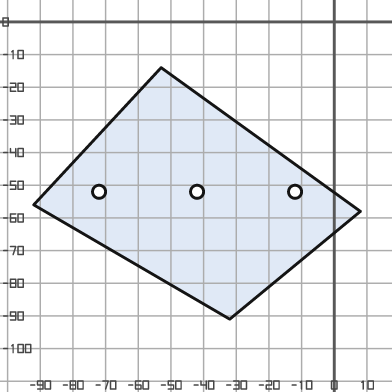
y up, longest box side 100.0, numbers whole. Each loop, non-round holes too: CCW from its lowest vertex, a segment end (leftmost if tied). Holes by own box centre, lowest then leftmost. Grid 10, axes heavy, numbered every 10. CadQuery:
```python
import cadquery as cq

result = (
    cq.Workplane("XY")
    .moveTo(-32.0, -91.0)
    .lineTo(8.0, -58.0)
    .lineTo(-53.0, -14.0)
    .lineTo(-92.0, -56.0)
    .close()
    .moveTo(-72.0, -52.0)
    .circle(2.0)
    .moveTo(-42.0, -52.0)
    .circle(2.0)
    .moveTo(-12.0, -52.0)
    .circle(2.0)
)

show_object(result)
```